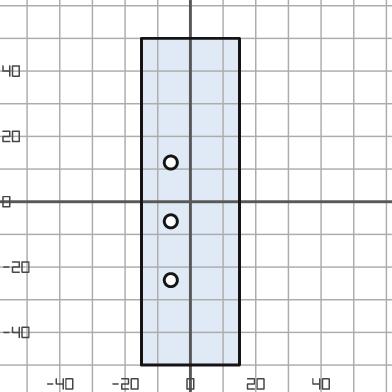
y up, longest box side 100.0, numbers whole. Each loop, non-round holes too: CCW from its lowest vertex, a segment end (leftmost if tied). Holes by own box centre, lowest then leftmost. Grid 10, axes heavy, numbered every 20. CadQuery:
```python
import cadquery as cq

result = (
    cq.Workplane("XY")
    .moveTo(-15.0, -50.0)
    .lineTo(15.0, -50.0)
    .lineTo(15.0, 50.0)
    .lineTo(-15.0, 50.0)
    .close()
    .moveTo(-6.0, -24.0)
    .circle(2.0)
    .moveTo(-6.0, -6.0)
    .circle(2.0)
    .moveTo(-6.0, 12.0)
    .circle(2.0)
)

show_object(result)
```